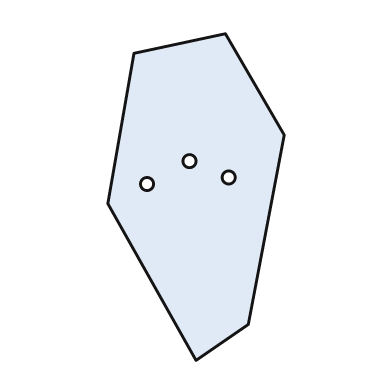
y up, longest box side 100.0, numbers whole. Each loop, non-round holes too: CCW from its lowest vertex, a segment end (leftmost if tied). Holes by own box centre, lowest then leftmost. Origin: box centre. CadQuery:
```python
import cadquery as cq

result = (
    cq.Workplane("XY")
    .moveTo(0.0, -50.0)
    .lineTo(16.0, -39.0)
    .lineTo(27.0, 19.0)
    .lineTo(9.0, 50.0)
    .lineTo(-19.0, 44.0)
    .lineTo(-27.0, -2.0)
    .close()
    .moveTo(-15.0, 4.0)
    .circle(2.0)
    .moveTo(10.0, 6.0)
    .circle(2.0)
    .moveTo(-2.0, 11.0)
    .circle(2.0)
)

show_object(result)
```